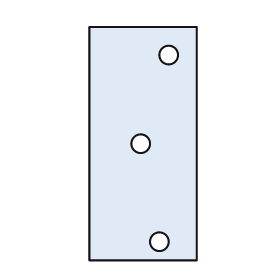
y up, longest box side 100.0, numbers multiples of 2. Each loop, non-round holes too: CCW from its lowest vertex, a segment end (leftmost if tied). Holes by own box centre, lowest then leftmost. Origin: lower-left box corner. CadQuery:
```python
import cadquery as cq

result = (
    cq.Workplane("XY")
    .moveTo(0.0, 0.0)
    .lineTo(46.0, 0.0)
    .lineTo(46.0, 100.0)
    .lineTo(0.0, 100.0)
    .close()
    .moveTo(30.0, 8.0)
    .circle(4.0)
    .moveTo(22.0, 50.0)
    .circle(4.0)
    .moveTo(34.0, 88.0)
    .circle(4.0)
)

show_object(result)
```